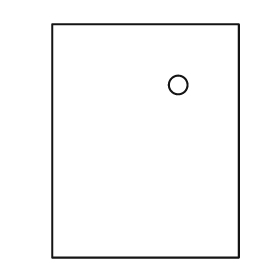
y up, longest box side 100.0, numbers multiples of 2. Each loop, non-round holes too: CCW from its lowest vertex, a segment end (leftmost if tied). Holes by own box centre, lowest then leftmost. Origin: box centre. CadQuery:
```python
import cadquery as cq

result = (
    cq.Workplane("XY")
    .moveTo(-40.0, -50.0)
    .lineTo(40.0, -50.0)
    .lineTo(40.0, 50.0)
    .lineTo(-40.0, 50.0)
    .close()
    .moveTo(14.0, 24.0)
    .circle(4.0)
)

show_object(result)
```